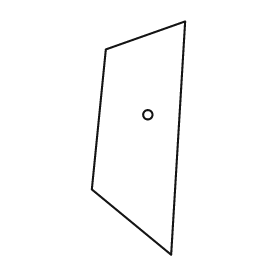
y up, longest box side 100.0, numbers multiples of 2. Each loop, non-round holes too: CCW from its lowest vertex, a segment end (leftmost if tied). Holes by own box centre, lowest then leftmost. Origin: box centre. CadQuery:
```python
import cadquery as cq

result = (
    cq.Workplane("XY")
    .moveTo(14.0, -50.0)
    .lineTo(20.0, 50.0)
    .lineTo(-14.0, 38.0)
    .lineTo(-20.0, -22.0)
    .close()
    .moveTo(4.0, 10.0)
    .circle(2.0)
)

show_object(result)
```